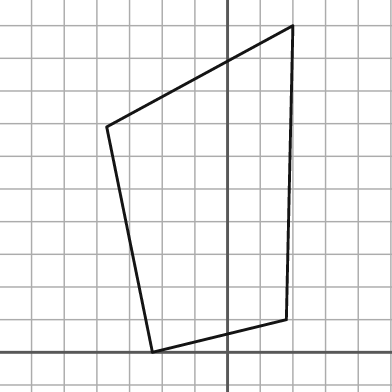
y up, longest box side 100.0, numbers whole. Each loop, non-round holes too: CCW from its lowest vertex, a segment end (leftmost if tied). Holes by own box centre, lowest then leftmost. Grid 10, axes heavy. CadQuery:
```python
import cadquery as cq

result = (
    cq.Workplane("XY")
    .moveTo(-23.0, 0.0)
    .lineTo(18.0, 10.0)
    .lineTo(20.0, 100.0)
    .lineTo(-37.0, 69.0)
    .close()
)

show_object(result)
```